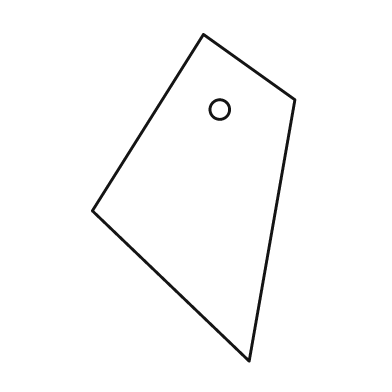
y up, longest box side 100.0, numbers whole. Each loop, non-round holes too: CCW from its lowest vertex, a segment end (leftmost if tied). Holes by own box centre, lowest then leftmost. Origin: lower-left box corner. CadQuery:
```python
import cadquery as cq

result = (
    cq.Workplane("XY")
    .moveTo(48.0, 0.0)
    .lineTo(62.0, 80.0)
    .lineTo(34.0, 100.0)
    .lineTo(0.0, 46.0)
    .close()
    .moveTo(39.0, 77.0)
    .circle(3.0)
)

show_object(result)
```